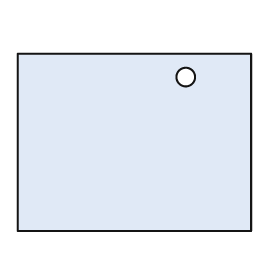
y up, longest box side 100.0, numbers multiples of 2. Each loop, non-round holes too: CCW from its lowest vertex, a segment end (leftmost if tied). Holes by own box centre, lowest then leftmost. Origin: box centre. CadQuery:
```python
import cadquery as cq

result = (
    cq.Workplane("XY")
    .moveTo(-50.0, -38.0)
    .lineTo(50.0, -38.0)
    .lineTo(50.0, 38.0)
    .lineTo(-50.0, 38.0)
    .close()
    .moveTo(22.0, 28.0)
    .circle(4.0)
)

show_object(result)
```